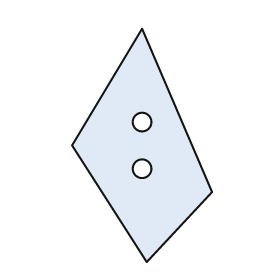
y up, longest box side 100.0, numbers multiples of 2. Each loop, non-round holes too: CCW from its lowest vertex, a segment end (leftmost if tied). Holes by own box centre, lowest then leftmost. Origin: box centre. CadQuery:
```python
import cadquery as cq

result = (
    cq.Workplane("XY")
    .moveTo(2.0, -50.0)
    .lineTo(30.0, -20.0)
    .lineTo(0.0, 50.0)
    .lineTo(-30.0, 0.0)
    .close()
    .moveTo(0.0, -10.0)
    .circle(4.0)
    .moveTo(0.0, 10.0)
    .circle(4.0)
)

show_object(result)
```